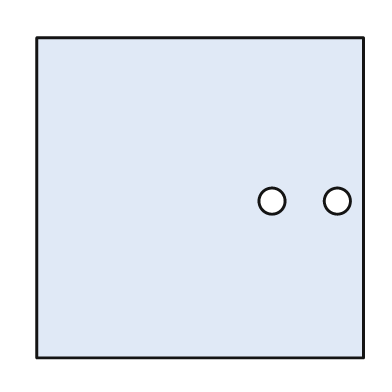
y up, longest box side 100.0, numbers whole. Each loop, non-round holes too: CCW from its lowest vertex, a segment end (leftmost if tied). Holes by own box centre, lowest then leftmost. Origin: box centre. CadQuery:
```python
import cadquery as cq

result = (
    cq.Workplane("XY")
    .moveTo(-50.0, -49.0)
    .lineTo(50.0, -49.0)
    .lineTo(50.0, 49.0)
    .lineTo(-50.0, 49.0)
    .close()
    .moveTo(22.0, -1.0)
    .circle(4.0)
    .moveTo(42.0, -1.0)
    .circle(4.0)
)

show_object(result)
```